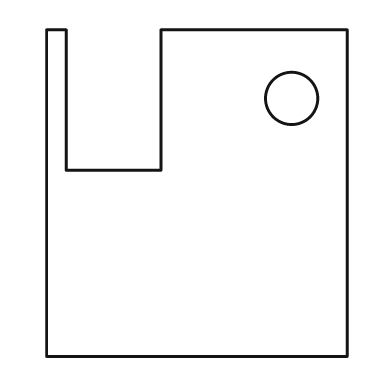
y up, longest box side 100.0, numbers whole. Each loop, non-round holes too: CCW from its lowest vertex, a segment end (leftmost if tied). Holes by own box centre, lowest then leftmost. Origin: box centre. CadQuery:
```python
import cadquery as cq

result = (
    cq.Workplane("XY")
    .moveTo(-46.0, -50.0)
    .lineTo(46.0, -50.0)
    .lineTo(46.0, 50.0)
    .lineTo(-11.0, 50.0)
    .lineTo(-11.0, 7.0)
    .lineTo(-40.0, 7.0)
    .lineTo(-40.0, 50.0)
    .lineTo(-46.0, 50.0)
    .close()
    .moveTo(29.0, 29.0)
    .circle(8.0)
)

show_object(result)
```